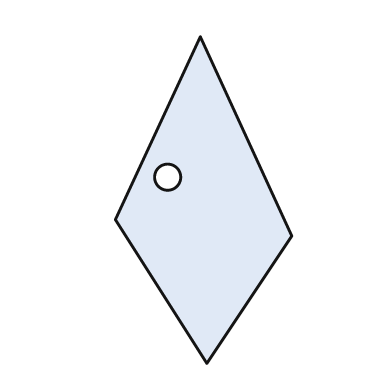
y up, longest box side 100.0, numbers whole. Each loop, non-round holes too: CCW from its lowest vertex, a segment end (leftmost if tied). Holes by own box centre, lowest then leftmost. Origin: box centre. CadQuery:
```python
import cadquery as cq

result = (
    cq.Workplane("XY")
    .moveTo(1.0, -50.0)
    .lineTo(27.0, -11.0)
    .lineTo(-1.0, 50.0)
    .lineTo(-27.0, -6.0)
    .close()
    .moveTo(-11.0, 7.0)
    .circle(4.0)
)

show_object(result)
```